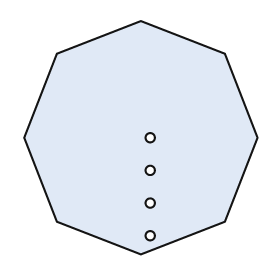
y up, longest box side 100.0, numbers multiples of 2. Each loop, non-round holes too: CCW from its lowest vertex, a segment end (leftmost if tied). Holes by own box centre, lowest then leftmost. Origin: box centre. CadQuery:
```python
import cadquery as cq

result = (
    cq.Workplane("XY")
    .moveTo(0.0, -50.0)
    .lineTo(36.0, -36.0)
    .lineTo(50.0, 0.0)
    .lineTo(36.0, 36.0)
    .lineTo(0.0, 50.0)
    .lineTo(-36.0, 36.0)
    .lineTo(-50.0, 0.0)
    .lineTo(-36.0, -36.0)
    .close()
    .moveTo(4.0, -42.0)
    .circle(2.0)
    .moveTo(4.0, -28.0)
    .circle(2.0)
    .moveTo(4.0, -14.0)
    .circle(2.0)
    .moveTo(4.0, 0.0)
    .circle(2.0)
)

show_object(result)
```